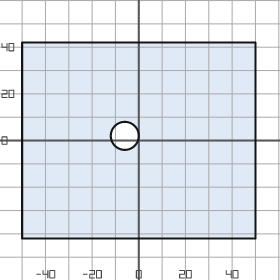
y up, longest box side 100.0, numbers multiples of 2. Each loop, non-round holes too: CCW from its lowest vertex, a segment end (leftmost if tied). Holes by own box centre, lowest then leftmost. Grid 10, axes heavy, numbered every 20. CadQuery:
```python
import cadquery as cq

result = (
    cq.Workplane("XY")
    .moveTo(-50.0, -42.0)
    .lineTo(50.0, -42.0)
    .lineTo(50.0, 42.0)
    .lineTo(-50.0, 42.0)
    .close()
    .moveTo(-6.0, 2.0)
    .circle(6.0)
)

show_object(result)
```